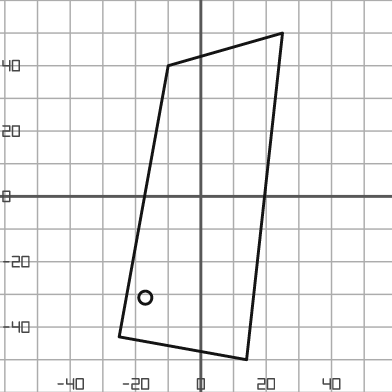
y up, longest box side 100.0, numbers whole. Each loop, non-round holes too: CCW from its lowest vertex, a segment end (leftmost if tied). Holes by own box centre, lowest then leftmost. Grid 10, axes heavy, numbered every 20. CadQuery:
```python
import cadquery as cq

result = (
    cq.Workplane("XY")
    .moveTo(14.0, -50.0)
    .lineTo(25.0, 50.0)
    .lineTo(-10.0, 40.0)
    .lineTo(-25.0, -43.0)
    .close()
    .moveTo(-17.0, -31.0)
    .circle(2.0)
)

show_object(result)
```